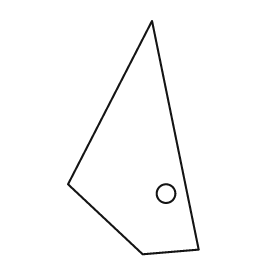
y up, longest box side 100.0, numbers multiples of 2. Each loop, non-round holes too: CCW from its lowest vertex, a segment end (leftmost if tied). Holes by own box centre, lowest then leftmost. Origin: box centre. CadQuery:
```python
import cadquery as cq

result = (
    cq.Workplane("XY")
    .moveTo(4.0, -50.0)
    .lineTo(28.0, -48.0)
    .lineTo(8.0, 50.0)
    .lineTo(-28.0, -20.0)
    .close()
    .moveTo(14.0, -24.0)
    .circle(4.0)
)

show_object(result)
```